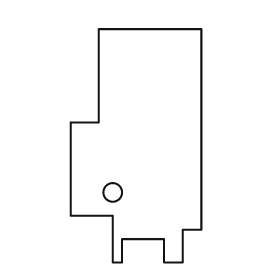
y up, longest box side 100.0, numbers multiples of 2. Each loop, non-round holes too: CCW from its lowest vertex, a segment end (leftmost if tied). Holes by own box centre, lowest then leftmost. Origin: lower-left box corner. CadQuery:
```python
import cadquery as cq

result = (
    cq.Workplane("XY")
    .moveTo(18.0, 0.0)
    .lineTo(22.0, 0.0)
    .lineTo(22.0, 10.0)
    .lineTo(40.0, 10.0)
    .lineTo(40.0, 0.0)
    .lineTo(48.0, 0.0)
    .lineTo(48.0, 14.0)
    .lineTo(56.0, 14.0)
    .lineTo(56.0, 100.0)
    .lineTo(12.0, 100.0)
    .lineTo(12.0, 60.0)
    .lineTo(0.0, 60.0)
    .lineTo(0.0, 20.0)
    .lineTo(18.0, 20.0)
    .close()
    .moveTo(18.0, 30.0)
    .circle(4.0)
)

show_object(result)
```